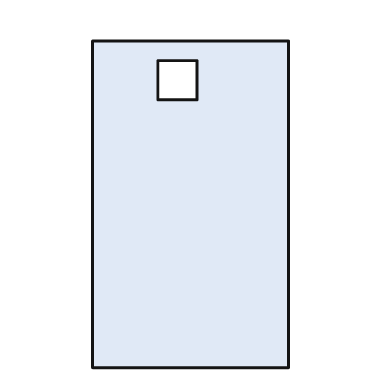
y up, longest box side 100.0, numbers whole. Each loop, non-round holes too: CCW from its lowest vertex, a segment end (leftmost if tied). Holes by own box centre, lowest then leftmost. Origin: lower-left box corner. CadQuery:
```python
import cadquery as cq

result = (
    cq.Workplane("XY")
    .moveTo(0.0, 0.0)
    .lineTo(60.0, 0.0)
    .lineTo(60.0, 100.0)
    .lineTo(0.0, 100.0)
    .close()
    .moveTo(20.0, 82.0)
    .lineTo(32.0, 82.0)
    .lineTo(32.0, 94.0)
    .lineTo(20.0, 94.0)
    .close()
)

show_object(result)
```